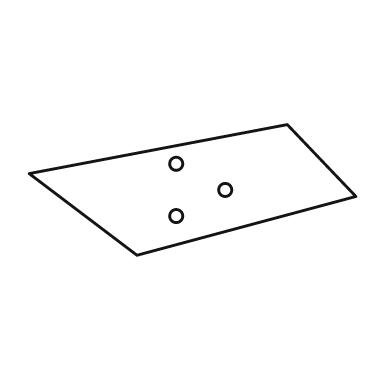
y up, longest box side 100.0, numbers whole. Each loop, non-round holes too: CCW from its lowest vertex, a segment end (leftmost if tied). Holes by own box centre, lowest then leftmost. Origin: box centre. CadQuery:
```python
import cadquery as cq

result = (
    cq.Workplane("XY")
    .moveTo(-17.0, -20.0)
    .lineTo(50.0, -2.0)
    .lineTo(29.0, 20.0)
    .lineTo(-50.0, 5.0)
    .close()
    .moveTo(-5.0, -8.0)
    .circle(2.0)
    .moveTo(10.0, 0.0)
    .circle(2.0)
    .moveTo(-5.0, 8.0)
    .circle(2.0)
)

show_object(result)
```